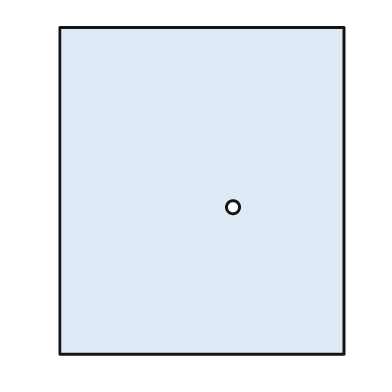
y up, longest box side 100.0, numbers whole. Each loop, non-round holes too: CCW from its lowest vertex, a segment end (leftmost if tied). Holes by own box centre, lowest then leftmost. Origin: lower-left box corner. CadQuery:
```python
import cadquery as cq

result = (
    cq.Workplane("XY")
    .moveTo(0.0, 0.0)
    .lineTo(87.0, 0.0)
    .lineTo(87.0, 100.0)
    .lineTo(0.0, 100.0)
    .close()
    .moveTo(53.0, 45.0)
    .circle(2.0)
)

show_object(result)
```